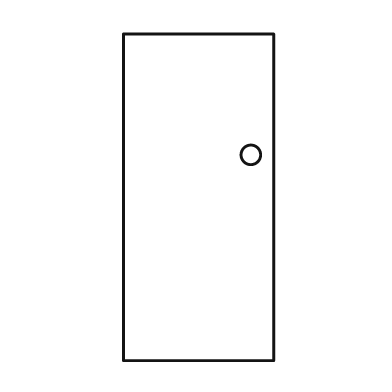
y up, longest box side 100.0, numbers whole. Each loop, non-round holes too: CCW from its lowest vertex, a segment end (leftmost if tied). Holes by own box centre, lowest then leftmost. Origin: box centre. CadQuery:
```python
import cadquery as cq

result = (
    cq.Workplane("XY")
    .moveTo(-23.0, -50.0)
    .lineTo(23.0, -50.0)
    .lineTo(23.0, 50.0)
    .lineTo(-23.0, 50.0)
    .close()
    .moveTo(16.0, 13.0)
    .circle(3.0)
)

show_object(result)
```